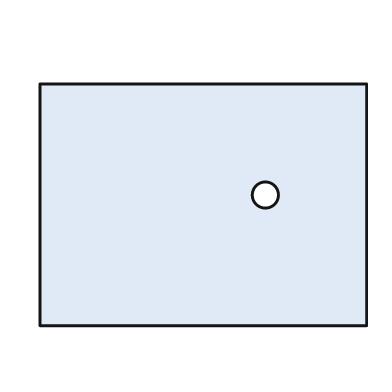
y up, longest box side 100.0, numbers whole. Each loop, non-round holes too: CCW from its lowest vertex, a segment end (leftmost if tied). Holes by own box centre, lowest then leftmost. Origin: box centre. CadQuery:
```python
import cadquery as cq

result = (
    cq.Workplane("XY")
    .moveTo(-50.0, -37.0)
    .lineTo(50.0, -37.0)
    .lineTo(50.0, 37.0)
    .lineTo(-50.0, 37.0)
    .close()
    .moveTo(19.0, 3.0)
    .circle(4.0)
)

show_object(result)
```